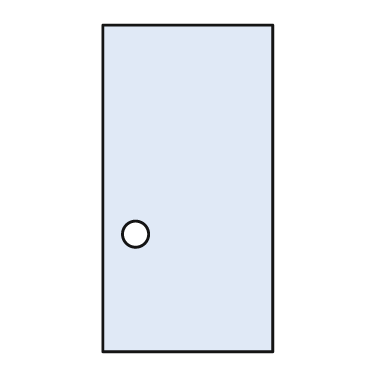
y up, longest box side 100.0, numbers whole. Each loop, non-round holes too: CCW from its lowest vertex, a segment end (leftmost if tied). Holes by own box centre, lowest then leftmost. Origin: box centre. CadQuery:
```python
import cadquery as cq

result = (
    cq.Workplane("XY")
    .moveTo(-26.0, -50.0)
    .lineTo(26.0, -50.0)
    .lineTo(26.0, 50.0)
    .lineTo(-26.0, 50.0)
    .close()
    .moveTo(-16.0, -14.0)
    .circle(4.0)
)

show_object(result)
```